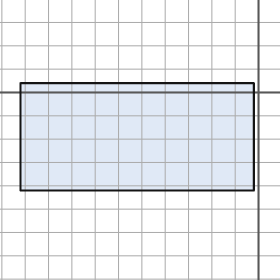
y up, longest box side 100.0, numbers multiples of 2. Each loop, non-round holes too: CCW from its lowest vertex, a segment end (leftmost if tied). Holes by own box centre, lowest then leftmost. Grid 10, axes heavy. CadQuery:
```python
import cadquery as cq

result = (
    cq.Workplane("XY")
    .moveTo(-102.0, -42.0)
    .lineTo(-2.0, -42.0)
    .lineTo(-2.0, 4.0)
    .lineTo(-102.0, 4.0)
    .close()
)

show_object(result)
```